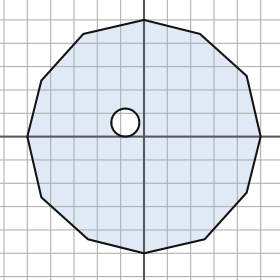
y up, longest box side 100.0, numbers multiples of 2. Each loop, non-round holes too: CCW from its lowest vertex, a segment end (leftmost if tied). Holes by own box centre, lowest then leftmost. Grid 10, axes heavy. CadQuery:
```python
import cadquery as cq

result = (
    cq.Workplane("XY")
    .moveTo(0.0, -50.0)
    .lineTo(26.0, -44.0)
    .lineTo(44.0, -24.0)
    .lineTo(50.0, 0.0)
    .lineTo(44.0, 26.0)
    .lineTo(24.0, 44.0)
    .lineTo(0.0, 50.0)
    .lineTo(-26.0, 44.0)
    .lineTo(-44.0, 24.0)
    .lineTo(-50.0, 0.0)
    .lineTo(-44.0, -26.0)
    .lineTo(-24.0, -44.0)
    .close()
    .moveTo(-8.0, 6.0)
    .circle(6.0)
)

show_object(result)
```